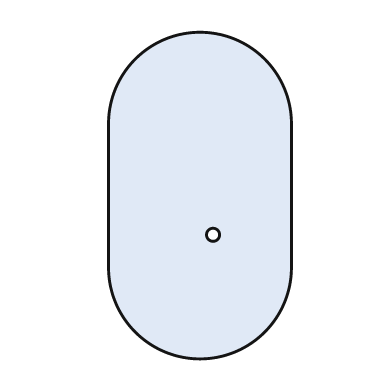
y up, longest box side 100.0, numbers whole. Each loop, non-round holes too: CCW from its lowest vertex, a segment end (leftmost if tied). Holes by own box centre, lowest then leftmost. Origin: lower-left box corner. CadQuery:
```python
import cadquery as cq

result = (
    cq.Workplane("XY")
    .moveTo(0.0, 28.0)
    .threePointArc((28.0, 0.0), (56.0, 28.0))
    .lineTo(56.0, 72.0)
    .threePointArc((28.0, 100.0), (0.0, 72.0))
    .close()
    .moveTo(32.0, 38.0)
    .circle(2.0)
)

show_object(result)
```